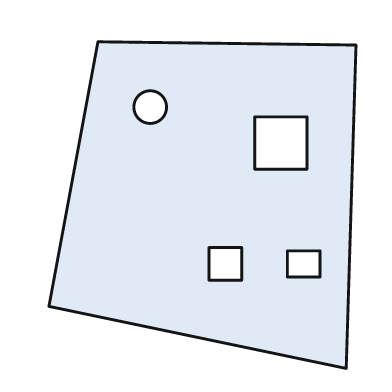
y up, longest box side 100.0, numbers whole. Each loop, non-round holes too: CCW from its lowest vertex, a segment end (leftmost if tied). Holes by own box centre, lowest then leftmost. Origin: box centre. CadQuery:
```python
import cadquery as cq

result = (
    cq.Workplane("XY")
    .moveTo(44.0, -50.0)
    .lineTo(47.0, 49.0)
    .lineTo(-32.0, 50.0)
    .lineTo(-47.0, -31.0)
    .close()
    .moveTo(2.0, -23.0)
    .lineTo(12.0, -23.0)
    .lineTo(12.0, -13.0)
    .lineTo(2.0, -13.0)
    .close()
    .moveTo(26.0, -22.0)
    .lineTo(36.0, -22.0)
    .lineTo(36.0, -14.0)
    .lineTo(26.0, -14.0)
    .close()
    .moveTo(16.0, 11.0)
    .lineTo(32.0, 11.0)
    .lineTo(32.0, 27.0)
    .lineTo(16.0, 27.0)
    .close()
    .moveTo(-16.0, 30.0)
    .circle(5.0)
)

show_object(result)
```